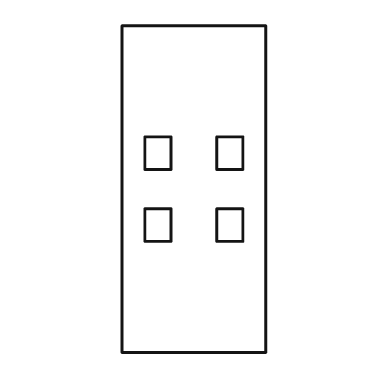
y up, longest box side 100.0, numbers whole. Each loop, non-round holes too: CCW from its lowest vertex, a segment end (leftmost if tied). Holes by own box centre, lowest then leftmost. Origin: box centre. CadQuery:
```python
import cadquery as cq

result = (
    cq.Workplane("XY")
    .moveTo(-22.0, -50.0)
    .lineTo(22.0, -50.0)
    .lineTo(22.0, 50.0)
    .lineTo(-22.0, 50.0)
    .close()
    .moveTo(-15.0, -16.0)
    .lineTo(-7.0, -16.0)
    .lineTo(-7.0, -6.0)
    .lineTo(-15.0, -6.0)
    .close()
    .moveTo(7.0, -16.0)
    .lineTo(15.0, -16.0)
    .lineTo(15.0, -6.0)
    .lineTo(7.0, -6.0)
    .close()
    .moveTo(-15.0, 6.0)
    .lineTo(-7.0, 6.0)
    .lineTo(-7.0, 16.0)
    .lineTo(-15.0, 16.0)
    .close()
    .moveTo(7.0, 6.0)
    .lineTo(15.0, 6.0)
    .lineTo(15.0, 16.0)
    .lineTo(7.0, 16.0)
    .close()
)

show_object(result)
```